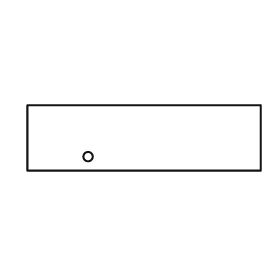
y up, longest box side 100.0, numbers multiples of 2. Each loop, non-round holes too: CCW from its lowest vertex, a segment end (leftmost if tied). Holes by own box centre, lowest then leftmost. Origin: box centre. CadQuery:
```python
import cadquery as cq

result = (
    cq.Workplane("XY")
    .moveTo(-50.0, -14.0)
    .lineTo(50.0, -14.0)
    .lineTo(50.0, 14.0)
    .lineTo(-50.0, 14.0)
    .close()
    .moveTo(-24.0, -8.0)
    .circle(2.0)
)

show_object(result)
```